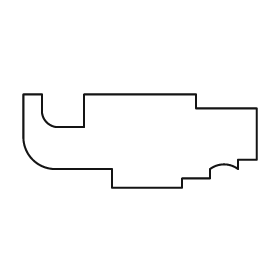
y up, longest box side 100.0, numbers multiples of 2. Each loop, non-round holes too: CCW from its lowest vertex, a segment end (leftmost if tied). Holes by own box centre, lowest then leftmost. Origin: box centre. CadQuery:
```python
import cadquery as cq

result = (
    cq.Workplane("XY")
    .moveTo(-12.0, -20.0)
    .lineTo(18.0, -20.0)
    .lineTo(18.0, -16.0)
    .lineTo(30.0, -16.0)
    .lineTo(30.0, -12.0)
    .threePointArc((36.0, -10.0), (42.0, -12.0))
    .lineTo(42.0, -8.0)
    .lineTo(50.0, -8.0)
    .lineTo(50.0, 14.0)
    .lineTo(24.0, 14.0)
    .lineTo(24.0, 20.0)
    .lineTo(-24.0, 20.0)
    .lineTo(-24.0, 6.0)
    .lineTo(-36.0, 6.0)
    .threePointArc((-40.0, 8.0), (-42.0, 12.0))
    .lineTo(-42.0, 20.0)
    .lineTo(-50.0, 20.0)
    .lineTo(-50.0, 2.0)
    .threePointArc((-46.0, -8.0), (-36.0, -12.0))
    .lineTo(-12.0, -12.0)
    .close()
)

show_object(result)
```